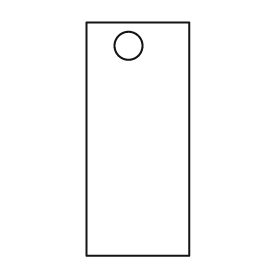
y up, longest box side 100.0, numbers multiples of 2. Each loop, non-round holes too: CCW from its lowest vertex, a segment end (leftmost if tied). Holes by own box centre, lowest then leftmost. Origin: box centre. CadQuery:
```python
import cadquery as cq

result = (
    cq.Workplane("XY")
    .moveTo(-22.0, -50.0)
    .lineTo(22.0, -50.0)
    .lineTo(22.0, 50.0)
    .lineTo(-22.0, 50.0)
    .close()
    .moveTo(-4.0, 40.0)
    .circle(6.0)
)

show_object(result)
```